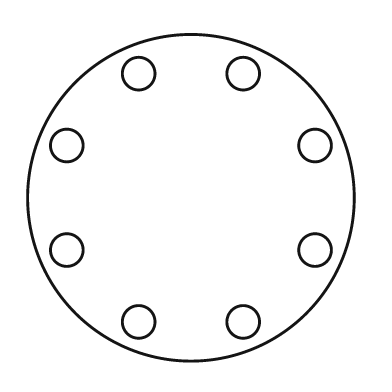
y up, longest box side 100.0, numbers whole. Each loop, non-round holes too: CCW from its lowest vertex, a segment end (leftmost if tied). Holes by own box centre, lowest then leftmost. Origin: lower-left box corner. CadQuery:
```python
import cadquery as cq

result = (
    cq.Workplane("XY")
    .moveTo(50.0, 50.0)
    .circle(50.0)
    .moveTo(34.0, 12.0)
    .circle(5.0)
    .moveTo(66.0, 12.0)
    .circle(5.0)
    .moveTo(12.0, 34.0)
    .circle(5.0)
    .moveTo(88.0, 34.0)
    .circle(5.0)
    .moveTo(12.0, 66.0)
    .circle(5.0)
    .moveTo(88.0, 66.0)
    .circle(5.0)
    .moveTo(34.0, 88.0)
    .circle(5.0)
    .moveTo(66.0, 88.0)
    .circle(5.0)
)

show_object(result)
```